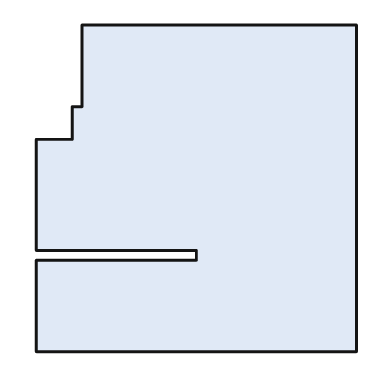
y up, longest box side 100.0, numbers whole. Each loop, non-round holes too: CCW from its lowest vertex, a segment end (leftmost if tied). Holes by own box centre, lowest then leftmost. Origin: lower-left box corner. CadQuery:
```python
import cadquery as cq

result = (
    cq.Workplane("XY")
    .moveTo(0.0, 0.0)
    .lineTo(98.0, 0.0)
    .lineTo(98.0, 100.0)
    .lineTo(14.0, 100.0)
    .lineTo(14.0, 75.0)
    .lineTo(11.0, 75.0)
    .lineTo(11.0, 65.0)
    .lineTo(0.0, 65.0)
    .lineTo(0.0, 31.0)
    .lineTo(49.0, 31.0)
    .lineTo(49.0, 28.0)
    .lineTo(0.0, 28.0)
    .close()
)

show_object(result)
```